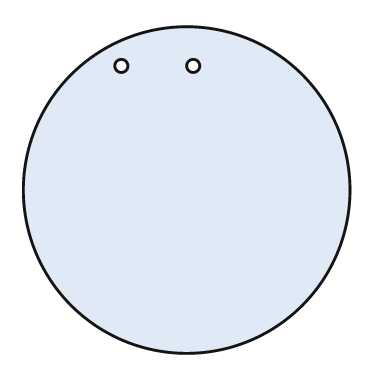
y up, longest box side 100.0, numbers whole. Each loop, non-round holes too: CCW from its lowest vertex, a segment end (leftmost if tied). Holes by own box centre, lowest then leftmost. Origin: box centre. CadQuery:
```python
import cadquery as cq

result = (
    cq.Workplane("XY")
    .moveTo(0.0, 0.0)
    .circle(50.0)
    .moveTo(-20.0, 38.0)
    .circle(2.0)
    .moveTo(2.0, 38.0)
    .circle(2.0)
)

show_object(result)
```